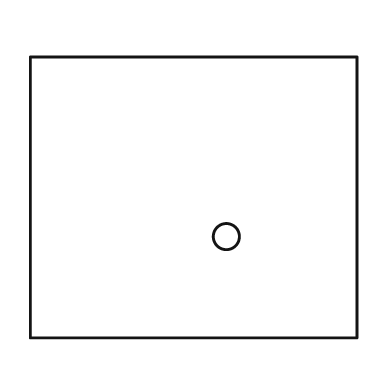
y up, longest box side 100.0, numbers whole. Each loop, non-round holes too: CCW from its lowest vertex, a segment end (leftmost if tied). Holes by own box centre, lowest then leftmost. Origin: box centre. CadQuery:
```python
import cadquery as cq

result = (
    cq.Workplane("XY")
    .moveTo(-50.0, -43.0)
    .lineTo(50.0, -43.0)
    .lineTo(50.0, 43.0)
    .lineTo(-50.0, 43.0)
    .close()
    .moveTo(10.0, -12.0)
    .circle(4.0)
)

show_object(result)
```